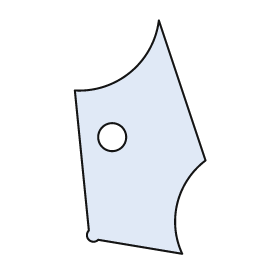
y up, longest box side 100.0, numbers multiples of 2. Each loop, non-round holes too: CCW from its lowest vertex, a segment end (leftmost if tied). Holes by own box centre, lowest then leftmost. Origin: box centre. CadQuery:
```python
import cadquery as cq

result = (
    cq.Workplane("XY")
    .moveTo(18.0, -50.0)
    .threePointArc((16.0, -28.0), (28.0, -10.0))
    .lineTo(8.0, 50.0)
    .threePointArc((-4.0, 28.0), (-28.0, 20.0))
    .lineTo(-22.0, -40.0)
    .threePointArc((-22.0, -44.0), (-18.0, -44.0))
    .close()
    .moveTo(-12.0, 0.0)
    .circle(6.0)
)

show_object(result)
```